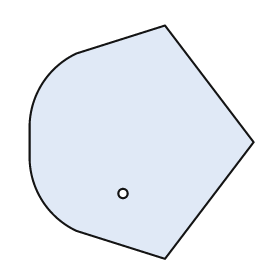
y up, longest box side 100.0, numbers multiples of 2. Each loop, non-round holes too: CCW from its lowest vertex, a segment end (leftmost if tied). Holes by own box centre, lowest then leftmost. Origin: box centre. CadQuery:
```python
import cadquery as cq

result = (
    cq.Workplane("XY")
    .moveTo(10.0, -50.0)
    .lineTo(48.0, 0.0)
    .lineTo(10.0, 50.0)
    .lineTo(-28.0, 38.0)
    .threePointArc((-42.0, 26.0), (-48.0, 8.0))
    .lineTo(-48.0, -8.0)
    .threePointArc((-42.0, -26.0), (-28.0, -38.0))
    .close()
    .moveTo(-8.0, -22.0)
    .circle(2.0)
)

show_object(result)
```